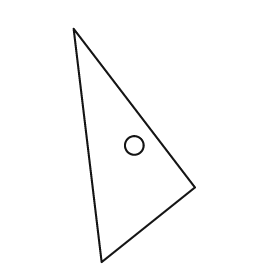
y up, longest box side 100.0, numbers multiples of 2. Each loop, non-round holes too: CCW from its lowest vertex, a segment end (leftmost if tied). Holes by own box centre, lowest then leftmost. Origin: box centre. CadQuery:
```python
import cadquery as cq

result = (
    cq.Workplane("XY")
    .moveTo(-14.0, -50.0)
    .lineTo(26.0, -18.0)
    .lineTo(-26.0, 50.0)
    .close()
    .moveTo(0.0, 0.0)
    .circle(4.0)
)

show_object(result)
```